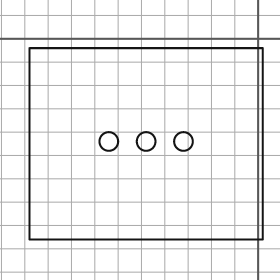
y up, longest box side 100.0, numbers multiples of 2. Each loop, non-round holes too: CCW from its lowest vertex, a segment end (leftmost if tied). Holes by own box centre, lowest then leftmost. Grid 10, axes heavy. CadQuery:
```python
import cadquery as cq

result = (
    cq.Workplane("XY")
    .moveTo(-98.0, -86.0)
    .lineTo(2.0, -86.0)
    .lineTo(2.0, -4.0)
    .lineTo(-98.0, -4.0)
    .close()
    .moveTo(-64.0, -44.0)
    .circle(4.0)
    .moveTo(-48.0, -44.0)
    .circle(4.0)
    .moveTo(-32.0, -44.0)
    .circle(4.0)
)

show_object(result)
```